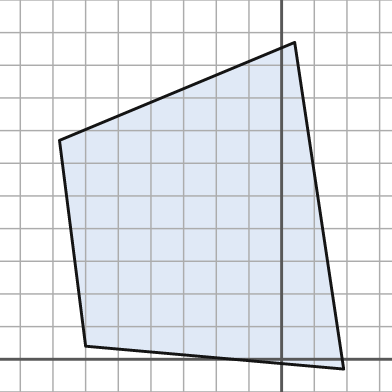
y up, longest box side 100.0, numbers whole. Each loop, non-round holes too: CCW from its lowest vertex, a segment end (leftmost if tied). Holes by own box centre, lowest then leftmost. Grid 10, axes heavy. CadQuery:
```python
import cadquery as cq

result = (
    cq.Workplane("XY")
    .moveTo(19.0, -3.0)
    .lineTo(4.0, 97.0)
    .lineTo(-68.0, 67.0)
    .lineTo(-60.0, 4.0)
    .close()
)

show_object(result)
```